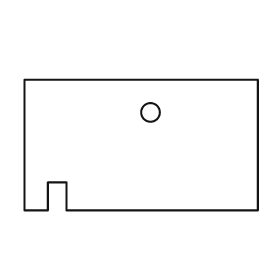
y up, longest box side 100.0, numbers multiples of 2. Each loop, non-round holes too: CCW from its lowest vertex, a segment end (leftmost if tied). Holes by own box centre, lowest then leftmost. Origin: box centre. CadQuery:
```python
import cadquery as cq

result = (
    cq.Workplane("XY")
    .moveTo(-50.0, -28.0)
    .lineTo(-40.0, -28.0)
    .lineTo(-40.0, -16.0)
    .lineTo(-32.0, -16.0)
    .lineTo(-32.0, -28.0)
    .lineTo(50.0, -28.0)
    .lineTo(50.0, 28.0)
    .lineTo(-50.0, 28.0)
    .close()
    .moveTo(4.0, 14.0)
    .circle(4.0)
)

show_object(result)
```